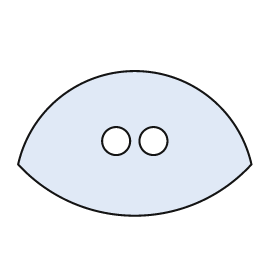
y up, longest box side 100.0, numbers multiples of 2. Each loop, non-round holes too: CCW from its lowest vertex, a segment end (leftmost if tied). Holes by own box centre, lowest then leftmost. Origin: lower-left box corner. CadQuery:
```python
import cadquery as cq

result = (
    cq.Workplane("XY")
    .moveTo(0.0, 22.0)
    .threePointArc((50.0, 0.0), (100.0, 22.0))
    .threePointArc((50.0, 62.0), (0.0, 22.0))
    .close()
    .moveTo(42.0, 32.0)
    .circle(6.0)
    .moveTo(58.0, 32.0)
    .circle(6.0)
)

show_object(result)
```